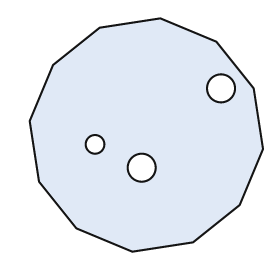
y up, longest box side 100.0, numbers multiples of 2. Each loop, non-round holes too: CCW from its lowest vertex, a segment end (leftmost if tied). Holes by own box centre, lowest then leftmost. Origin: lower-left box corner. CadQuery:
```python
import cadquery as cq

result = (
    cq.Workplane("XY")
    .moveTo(44.0, 0.0)
    .lineTo(70.0, 4.0)
    .lineTo(90.0, 20.0)
    .lineTo(100.0, 44.0)
    .lineTo(96.0, 70.0)
    .lineTo(80.0, 90.0)
    .lineTo(56.0, 100.0)
    .lineTo(30.0, 96.0)
    .lineTo(10.0, 80.0)
    .lineTo(0.0, 56.0)
    .lineTo(4.0, 30.0)
    .lineTo(20.0, 10.0)
    .close()
    .moveTo(48.0, 36.0)
    .circle(6.0)
    .moveTo(28.0, 46.0)
    .circle(4.0)
    .moveTo(82.0, 70.0)
    .circle(6.0)
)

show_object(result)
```